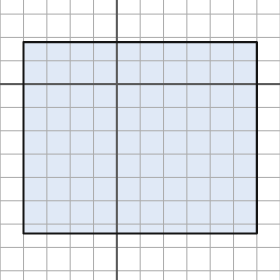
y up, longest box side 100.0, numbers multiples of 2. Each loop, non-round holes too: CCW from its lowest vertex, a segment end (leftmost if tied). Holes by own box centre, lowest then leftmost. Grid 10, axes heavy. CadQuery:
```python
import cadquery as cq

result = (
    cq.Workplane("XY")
    .moveTo(-40.0, -64.0)
    .lineTo(60.0, -64.0)
    .lineTo(60.0, 18.0)
    .lineTo(-40.0, 18.0)
    .close()
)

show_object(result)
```